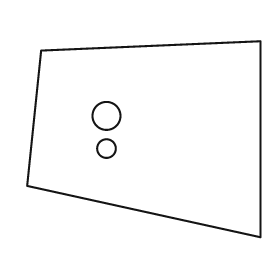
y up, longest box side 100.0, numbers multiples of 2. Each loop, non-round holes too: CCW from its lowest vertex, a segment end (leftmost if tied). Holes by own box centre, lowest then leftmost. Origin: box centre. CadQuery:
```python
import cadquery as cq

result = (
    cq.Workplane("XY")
    .moveTo(50.0, -42.0)
    .lineTo(50.0, 42.0)
    .lineTo(-44.0, 38.0)
    .lineTo(-50.0, -20.0)
    .close()
    .moveTo(-16.0, -4.0)
    .circle(4.0)
    .moveTo(-16.0, 10.0)
    .circle(6.0)
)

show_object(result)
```